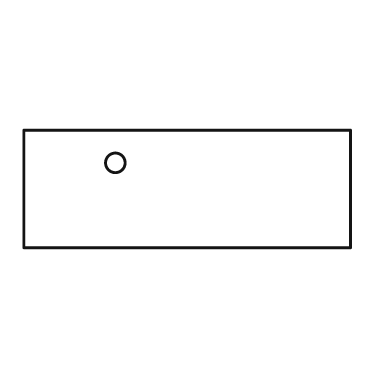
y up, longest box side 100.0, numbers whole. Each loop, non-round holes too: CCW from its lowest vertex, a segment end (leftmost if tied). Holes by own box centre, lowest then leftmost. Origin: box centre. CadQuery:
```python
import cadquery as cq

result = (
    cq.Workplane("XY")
    .moveTo(-50.0, -18.0)
    .lineTo(50.0, -18.0)
    .lineTo(50.0, 18.0)
    .lineTo(-50.0, 18.0)
    .close()
    .moveTo(-22.0, 8.0)
    .circle(3.0)
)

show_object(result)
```